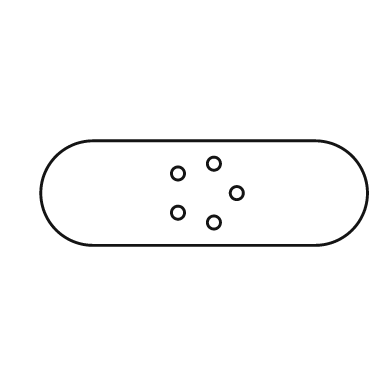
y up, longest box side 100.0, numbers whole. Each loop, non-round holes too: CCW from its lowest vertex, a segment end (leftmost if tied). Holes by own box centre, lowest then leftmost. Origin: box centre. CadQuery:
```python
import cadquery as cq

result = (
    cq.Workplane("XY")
    .moveTo(-34.0, -16.0)
    .lineTo(34.0, -16.0)
    .threePointArc((50.0, 0.0), (34.0, 16.0))
    .lineTo(-34.0, 16.0)
    .threePointArc((-50.0, 0.0), (-34.0, -16.0))
    .close()
    .moveTo(3.0, -9.0)
    .circle(2.0)
    .moveTo(-8.0, -6.0)
    .circle(2.0)
    .moveTo(10.0, 0.0)
    .circle(2.0)
    .moveTo(-8.0, 6.0)
    .circle(2.0)
    .moveTo(3.0, 9.0)
    .circle(2.0)
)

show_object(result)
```